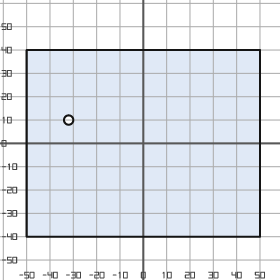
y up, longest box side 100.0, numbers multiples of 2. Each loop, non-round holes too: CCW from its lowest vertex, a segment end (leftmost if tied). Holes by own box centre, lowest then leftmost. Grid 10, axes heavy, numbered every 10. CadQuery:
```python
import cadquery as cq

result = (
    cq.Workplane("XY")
    .moveTo(-50.0, -40.0)
    .lineTo(50.0, -40.0)
    .lineTo(50.0, 40.0)
    .lineTo(-50.0, 40.0)
    .close()
    .moveTo(-32.0, 10.0)
    .circle(2.0)
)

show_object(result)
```